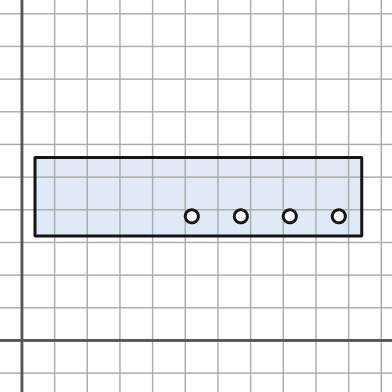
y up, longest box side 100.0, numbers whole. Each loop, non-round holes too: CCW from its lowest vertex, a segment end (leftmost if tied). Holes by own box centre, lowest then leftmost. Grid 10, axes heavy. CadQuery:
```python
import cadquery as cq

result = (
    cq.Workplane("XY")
    .moveTo(4.0, 32.0)
    .lineTo(104.0, 32.0)
    .lineTo(104.0, 56.0)
    .lineTo(4.0, 56.0)
    .close()
    .moveTo(52.0, 38.0)
    .circle(2.0)
    .moveTo(67.0, 38.0)
    .circle(2.0)
    .moveTo(82.0, 38.0)
    .circle(2.0)
    .moveTo(97.0, 38.0)
    .circle(2.0)
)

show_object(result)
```